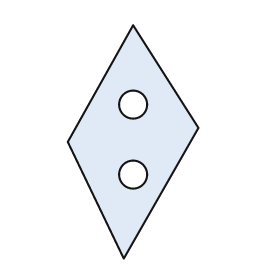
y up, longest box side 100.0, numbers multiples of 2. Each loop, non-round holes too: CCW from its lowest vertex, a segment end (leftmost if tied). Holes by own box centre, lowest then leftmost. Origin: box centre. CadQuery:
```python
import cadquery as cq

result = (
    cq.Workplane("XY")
    .moveTo(-4.0, -50.0)
    .lineTo(28.0, 6.0)
    .lineTo(0.0, 50.0)
    .lineTo(-28.0, 0.0)
    .close()
    .moveTo(0.0, -14.0)
    .circle(6.0)
    .moveTo(0.0, 16.0)
    .circle(6.0)
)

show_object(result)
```